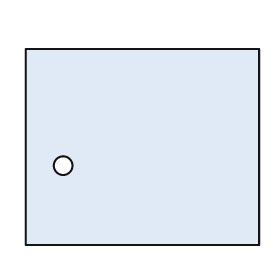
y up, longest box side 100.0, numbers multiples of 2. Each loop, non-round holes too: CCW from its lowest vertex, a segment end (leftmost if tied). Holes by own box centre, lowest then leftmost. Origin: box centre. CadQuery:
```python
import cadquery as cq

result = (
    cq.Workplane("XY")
    .moveTo(-50.0, -42.0)
    .lineTo(50.0, -42.0)
    .lineTo(50.0, 42.0)
    .lineTo(-50.0, 42.0)
    .close()
    .moveTo(-34.0, -8.0)
    .circle(4.0)
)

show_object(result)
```